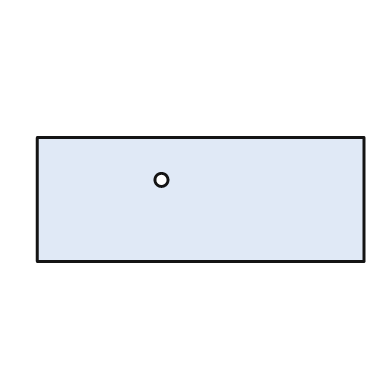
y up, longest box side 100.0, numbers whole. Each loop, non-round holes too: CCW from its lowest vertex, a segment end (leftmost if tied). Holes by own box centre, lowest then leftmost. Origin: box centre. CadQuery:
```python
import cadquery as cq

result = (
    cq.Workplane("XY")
    .moveTo(-50.0, -19.0)
    .lineTo(50.0, -19.0)
    .lineTo(50.0, 19.0)
    .lineTo(-50.0, 19.0)
    .close()
    .moveTo(-12.0, 6.0)
    .circle(2.0)
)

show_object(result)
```